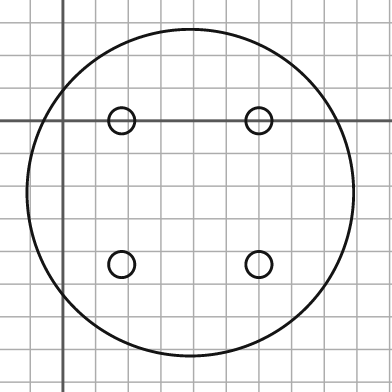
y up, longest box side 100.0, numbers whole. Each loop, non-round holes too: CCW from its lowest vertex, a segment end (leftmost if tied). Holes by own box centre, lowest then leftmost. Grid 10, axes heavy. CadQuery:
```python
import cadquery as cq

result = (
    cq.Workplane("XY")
    .moveTo(39.0, -22.0)
    .circle(50.0)
    .moveTo(18.0, -44.0)
    .circle(4.0)
    .moveTo(60.0, -44.0)
    .circle(4.0)
    .moveTo(18.0, 0.0)
    .circle(4.0)
    .moveTo(60.0, 0.0)
    .circle(4.0)
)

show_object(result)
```